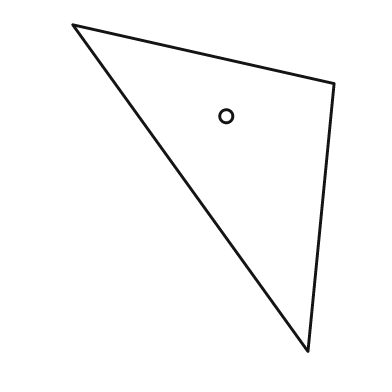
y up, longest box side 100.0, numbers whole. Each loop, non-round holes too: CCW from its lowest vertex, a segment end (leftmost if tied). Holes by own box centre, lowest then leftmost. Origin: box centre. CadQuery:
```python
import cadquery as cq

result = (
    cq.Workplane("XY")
    .moveTo(32.0, -50.0)
    .lineTo(40.0, 32.0)
    .lineTo(-40.0, 50.0)
    .close()
    .moveTo(7.0, 22.0)
    .circle(2.0)
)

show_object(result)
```